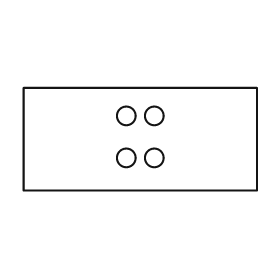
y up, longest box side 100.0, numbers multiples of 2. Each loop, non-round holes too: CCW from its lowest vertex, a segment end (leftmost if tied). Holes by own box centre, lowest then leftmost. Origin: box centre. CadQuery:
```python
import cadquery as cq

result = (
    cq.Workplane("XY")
    .moveTo(-50.0, -22.0)
    .lineTo(50.0, -22.0)
    .lineTo(50.0, 22.0)
    .lineTo(-50.0, 22.0)
    .close()
    .moveTo(-6.0, -8.0)
    .circle(4.0)
    .moveTo(6.0, -8.0)
    .circle(4.0)
    .moveTo(-6.0, 10.0)
    .circle(4.0)
    .moveTo(6.0, 10.0)
    .circle(4.0)
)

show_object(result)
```